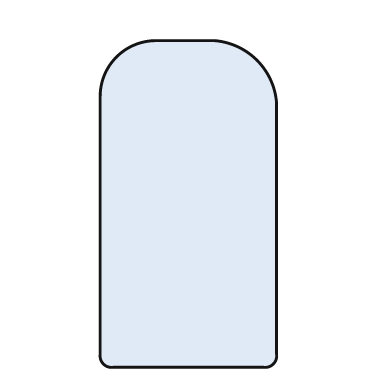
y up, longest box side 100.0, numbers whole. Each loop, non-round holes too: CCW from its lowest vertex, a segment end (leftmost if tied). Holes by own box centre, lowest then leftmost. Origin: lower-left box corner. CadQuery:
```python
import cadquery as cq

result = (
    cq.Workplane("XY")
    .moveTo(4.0, 0.0)
    .lineTo(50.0, 0.0)
    .threePointArc((53.0, 1.0), (54.0, 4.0))
    .lineTo(54.0, 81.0)
    .threePointArc((48.0, 94.0), (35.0, 100.0))
    .lineTo(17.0, 100.0)
    .threePointArc((5.0, 95.0), (0.0, 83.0))
    .lineTo(0.0, 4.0)
    .threePointArc((1.0, 1.0), (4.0, 0.0))
    .close()
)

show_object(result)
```